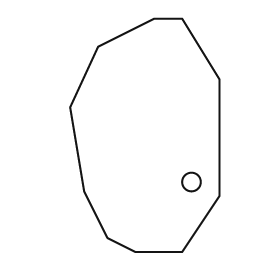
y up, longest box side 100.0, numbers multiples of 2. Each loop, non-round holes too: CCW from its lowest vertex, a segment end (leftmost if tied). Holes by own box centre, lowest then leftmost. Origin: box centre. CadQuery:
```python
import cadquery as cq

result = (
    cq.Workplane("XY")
    .moveTo(-4.0, -50.0)
    .lineTo(16.0, -50.0)
    .lineTo(32.0, -26.0)
    .lineTo(32.0, 24.0)
    .lineTo(16.0, 50.0)
    .lineTo(4.0, 50.0)
    .lineTo(-20.0, 38.0)
    .lineTo(-32.0, 12.0)
    .lineTo(-26.0, -24.0)
    .lineTo(-16.0, -44.0)
    .close()
    .moveTo(20.0, -20.0)
    .circle(4.0)
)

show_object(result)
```